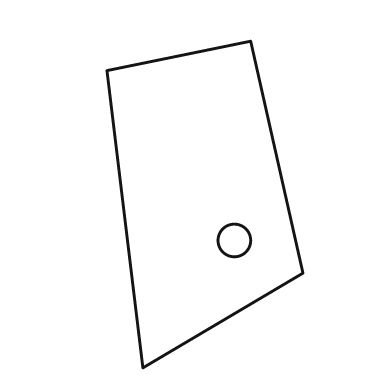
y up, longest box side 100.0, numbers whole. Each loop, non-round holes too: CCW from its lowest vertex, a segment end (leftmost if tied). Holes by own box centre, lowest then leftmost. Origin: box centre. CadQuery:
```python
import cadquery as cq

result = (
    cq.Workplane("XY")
    .moveTo(-19.0, -50.0)
    .lineTo(30.0, -21.0)
    .lineTo(14.0, 50.0)
    .lineTo(-30.0, 41.0)
    .close()
    .moveTo(9.0, -11.0)
    .circle(5.0)
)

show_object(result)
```